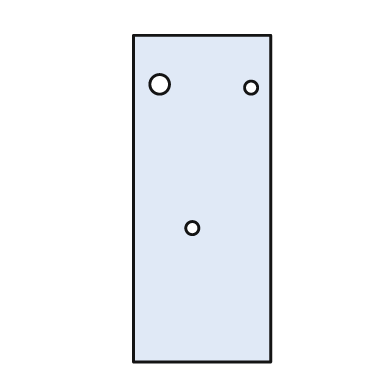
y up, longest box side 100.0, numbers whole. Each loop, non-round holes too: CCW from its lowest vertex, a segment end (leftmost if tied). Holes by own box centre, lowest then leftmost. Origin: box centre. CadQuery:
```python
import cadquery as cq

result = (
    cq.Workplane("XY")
    .moveTo(-21.0, -50.0)
    .lineTo(21.0, -50.0)
    .lineTo(21.0, 50.0)
    .lineTo(-21.0, 50.0)
    .close()
    .moveTo(-3.0, -9.0)
    .circle(2.0)
    .moveTo(15.0, 34.0)
    .circle(2.0)
    .moveTo(-13.0, 35.0)
    .circle(3.0)
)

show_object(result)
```